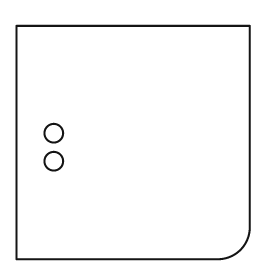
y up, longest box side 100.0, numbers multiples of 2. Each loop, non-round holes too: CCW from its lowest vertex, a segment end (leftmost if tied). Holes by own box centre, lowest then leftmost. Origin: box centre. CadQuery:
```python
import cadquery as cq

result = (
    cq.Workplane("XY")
    .moveTo(-50.0, -50.0)
    .lineTo(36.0, -50.0)
    .threePointArc((46.0, -46.0), (50.0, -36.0))
    .lineTo(50.0, 50.0)
    .lineTo(-50.0, 50.0)
    .close()
    .moveTo(-34.0, -8.0)
    .circle(4.0)
    .moveTo(-34.0, 4.0)
    .circle(4.0)
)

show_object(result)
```